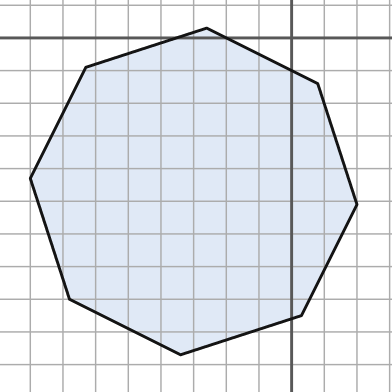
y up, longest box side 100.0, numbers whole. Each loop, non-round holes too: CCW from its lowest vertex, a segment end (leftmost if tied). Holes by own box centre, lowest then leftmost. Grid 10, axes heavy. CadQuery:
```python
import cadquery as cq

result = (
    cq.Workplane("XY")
    .moveTo(-34.0, -97.0)
    .lineTo(3.0, -85.0)
    .lineTo(20.0, -51.0)
    .lineTo(8.0, -14.0)
    .lineTo(-26.0, 3.0)
    .lineTo(-63.0, -9.0)
    .lineTo(-80.0, -43.0)
    .lineTo(-68.0, -80.0)
    .close()
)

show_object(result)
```